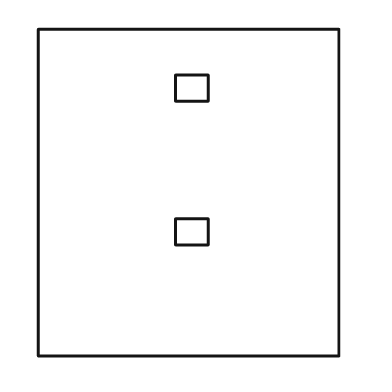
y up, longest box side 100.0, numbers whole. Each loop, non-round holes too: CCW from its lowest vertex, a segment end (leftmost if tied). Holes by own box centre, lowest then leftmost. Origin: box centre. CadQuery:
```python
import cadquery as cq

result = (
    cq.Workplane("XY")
    .moveTo(-46.0, -50.0)
    .lineTo(46.0, -50.0)
    .lineTo(46.0, 50.0)
    .lineTo(-46.0, 50.0)
    .close()
    .moveTo(-4.0, -16.0)
    .lineTo(6.0, -16.0)
    .lineTo(6.0, -8.0)
    .lineTo(-4.0, -8.0)
    .close()
    .moveTo(-4.0, 28.0)
    .lineTo(6.0, 28.0)
    .lineTo(6.0, 36.0)
    .lineTo(-4.0, 36.0)
    .close()
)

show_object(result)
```